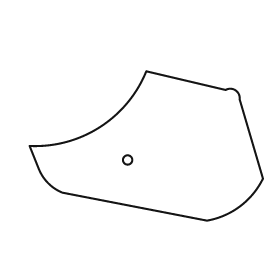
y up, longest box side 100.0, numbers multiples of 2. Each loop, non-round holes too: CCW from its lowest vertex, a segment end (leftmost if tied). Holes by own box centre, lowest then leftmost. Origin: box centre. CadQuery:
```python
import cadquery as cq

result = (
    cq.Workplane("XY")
    .moveTo(26.0, -32.0)
    .threePointArc((40.0, -26.0), (50.0, -14.0))
    .lineTo(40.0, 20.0)
    .threePointArc((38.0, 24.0), (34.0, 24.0))
    .lineTo(0.0, 32.0)
    .threePointArc((-20.0, 8.0), (-50.0, 0.0))
    .lineTo(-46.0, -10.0)
    .threePointArc((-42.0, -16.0), (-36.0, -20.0))
    .close()
    .moveTo(-8.0, -6.0)
    .circle(2.0)
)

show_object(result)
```